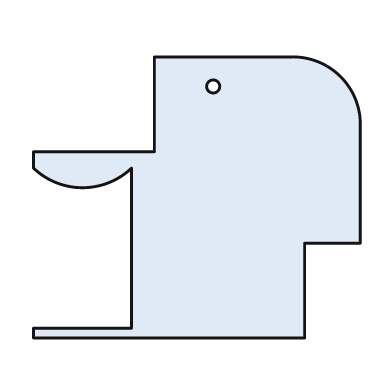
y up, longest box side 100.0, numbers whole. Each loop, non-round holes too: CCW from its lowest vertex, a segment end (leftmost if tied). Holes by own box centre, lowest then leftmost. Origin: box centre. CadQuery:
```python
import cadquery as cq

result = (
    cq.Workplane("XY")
    .moveTo(-50.0, -43.0)
    .lineTo(33.0, -43.0)
    .lineTo(33.0, -14.0)
    .lineTo(50.0, -14.0)
    .lineTo(50.0, 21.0)
    .threePointArc((44.0, 37.0), (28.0, 43.0))
    .lineTo(-13.0, 43.0)
    .lineTo(-13.0, 14.0)
    .lineTo(-50.0, 14.0)
    .lineTo(-50.0, 9.0)
    .threePointArc((-35.0, 3.0), (-20.0, 9.0))
    .lineTo(-20.0, -40.0)
    .lineTo(-50.0, -40.0)
    .close()
    .moveTo(5.0, 34.0)
    .circle(2.0)
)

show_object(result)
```